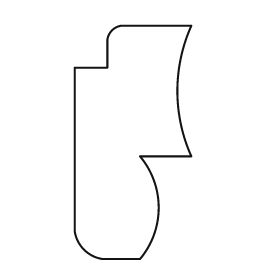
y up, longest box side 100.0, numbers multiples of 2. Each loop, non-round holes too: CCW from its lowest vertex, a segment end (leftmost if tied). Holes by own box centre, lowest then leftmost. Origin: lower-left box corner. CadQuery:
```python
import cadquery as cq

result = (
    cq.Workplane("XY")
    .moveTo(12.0, 0.0)
    .lineTo(28.0, 0.0)
    .threePointArc((36.0, 22.0), (28.0, 44.0))
    .lineTo(50.0, 44.0)
    .threePointArc((44.0, 72.0), (50.0, 100.0))
    .lineTo(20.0, 100.0)
    .threePointArc((16.0, 98.0), (14.0, 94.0))
    .lineTo(14.0, 82.0)
    .lineTo(0.0, 82.0)
    .lineTo(0.0, 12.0)
    .threePointArc((4.0, 4.0), (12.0, 0.0))
    .close()
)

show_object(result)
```